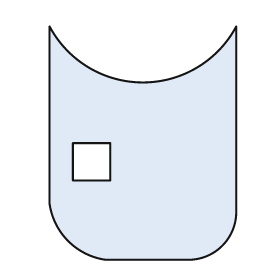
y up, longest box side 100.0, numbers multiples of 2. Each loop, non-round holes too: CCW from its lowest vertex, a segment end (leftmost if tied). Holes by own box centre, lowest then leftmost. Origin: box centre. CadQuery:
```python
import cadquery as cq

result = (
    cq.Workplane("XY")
    .moveTo(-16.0, -50.0)
    .lineTo(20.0, -50.0)
    .threePointArc((34.0, -44.0), (40.0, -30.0))
    .lineTo(40.0, 50.0)
    .threePointArc((0.0, 26.0), (-40.0, 50.0))
    .lineTo(-40.0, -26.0)
    .threePointArc((-32.0, -42.0), (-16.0, -50.0))
    .close()
    .moveTo(-30.0, -16.0)
    .lineTo(-14.0, -16.0)
    .lineTo(-14.0, 0.0)
    .lineTo(-30.0, 0.0)
    .close()
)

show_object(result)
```